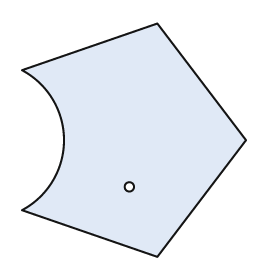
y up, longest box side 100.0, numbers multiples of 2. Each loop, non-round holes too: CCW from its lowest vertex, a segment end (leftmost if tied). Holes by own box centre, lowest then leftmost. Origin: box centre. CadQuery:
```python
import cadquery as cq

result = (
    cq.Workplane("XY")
    .moveTo(10.0, -50.0)
    .lineTo(48.0, 0.0)
    .lineTo(10.0, 50.0)
    .lineTo(-48.0, 30.0)
    .threePointArc((-30.0, 0.0), (-48.0, -30.0))
    .close()
    .moveTo(-2.0, -20.0)
    .circle(2.0)
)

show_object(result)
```